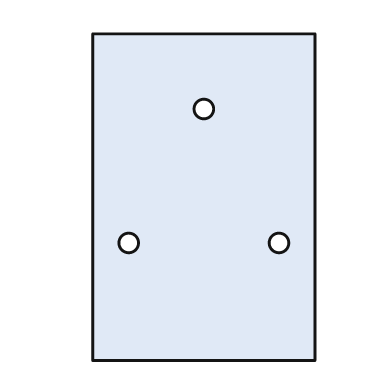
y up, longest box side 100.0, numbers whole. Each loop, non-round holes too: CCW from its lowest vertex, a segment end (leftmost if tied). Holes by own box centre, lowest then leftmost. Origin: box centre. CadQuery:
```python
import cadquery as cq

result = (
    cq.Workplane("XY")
    .moveTo(-34.0, -50.0)
    .lineTo(34.0, -50.0)
    .lineTo(34.0, 50.0)
    .lineTo(-34.0, 50.0)
    .close()
    .moveTo(-23.0, -14.0)
    .circle(3.0)
    .moveTo(23.0, -14.0)
    .circle(3.0)
    .moveTo(0.0, 27.0)
    .circle(3.0)
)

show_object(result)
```